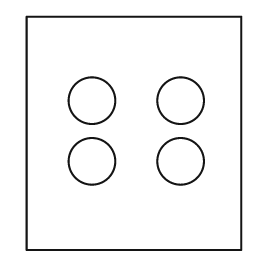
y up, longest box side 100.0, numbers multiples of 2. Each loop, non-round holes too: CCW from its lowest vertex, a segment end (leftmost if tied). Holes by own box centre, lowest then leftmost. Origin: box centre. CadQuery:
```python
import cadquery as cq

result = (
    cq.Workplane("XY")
    .moveTo(-46.0, -50.0)
    .lineTo(46.0, -50.0)
    .lineTo(46.0, 50.0)
    .lineTo(-46.0, 50.0)
    .close()
    .moveTo(-18.0, -12.0)
    .circle(10.0)
    .moveTo(20.0, -12.0)
    .circle(10.0)
    .moveTo(-18.0, 14.0)
    .circle(10.0)
    .moveTo(20.0, 14.0)
    .circle(10.0)
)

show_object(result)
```